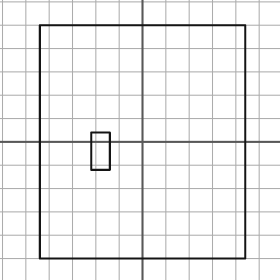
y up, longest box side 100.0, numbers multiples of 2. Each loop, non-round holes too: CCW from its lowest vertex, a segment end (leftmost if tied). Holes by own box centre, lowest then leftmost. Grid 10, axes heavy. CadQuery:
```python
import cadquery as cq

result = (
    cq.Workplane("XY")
    .moveTo(-44.0, -50.0)
    .lineTo(44.0, -50.0)
    .lineTo(44.0, 50.0)
    .lineTo(-44.0, 50.0)
    .close()
    .moveTo(-22.0, -12.0)
    .lineTo(-14.0, -12.0)
    .lineTo(-14.0, 4.0)
    .lineTo(-22.0, 4.0)
    .close()
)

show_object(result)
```